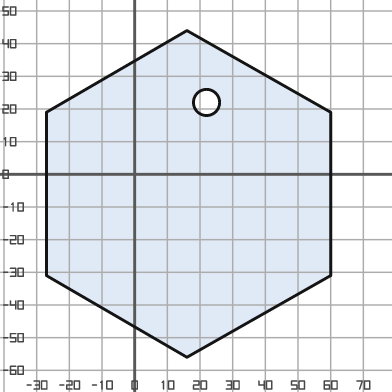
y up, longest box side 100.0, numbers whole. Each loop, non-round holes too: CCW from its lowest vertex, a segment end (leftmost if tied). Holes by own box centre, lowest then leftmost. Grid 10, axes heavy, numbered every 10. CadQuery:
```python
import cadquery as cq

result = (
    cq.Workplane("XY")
    .moveTo(16.0, -56.0)
    .lineTo(60.0, -31.0)
    .lineTo(60.0, 19.0)
    .lineTo(16.0, 44.0)
    .lineTo(-27.0, 19.0)
    .lineTo(-27.0, -31.0)
    .close()
    .moveTo(22.0, 22.0)
    .circle(4.0)
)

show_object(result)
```